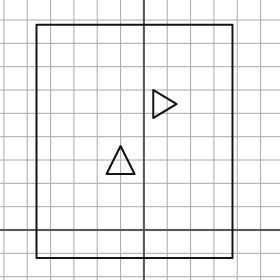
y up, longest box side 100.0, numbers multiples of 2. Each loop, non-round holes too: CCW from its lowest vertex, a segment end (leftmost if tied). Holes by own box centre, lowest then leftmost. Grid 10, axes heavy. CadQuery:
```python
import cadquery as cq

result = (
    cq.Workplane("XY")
    .moveTo(-46.0, -12.0)
    .lineTo(38.0, -12.0)
    .lineTo(38.0, 88.0)
    .lineTo(-46.0, 88.0)
    .close()
    .moveTo(-16.0, 24.0)
    .lineTo(-4.0, 24.0)
    .lineTo(-10.0, 36.0)
    .close()
    .moveTo(4.0, 48.0)
    .lineTo(14.0, 54.0)
    .lineTo(4.0, 60.0)
    .close()
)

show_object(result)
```